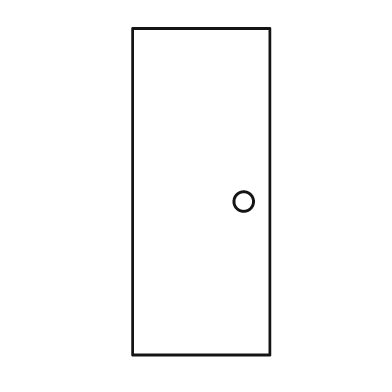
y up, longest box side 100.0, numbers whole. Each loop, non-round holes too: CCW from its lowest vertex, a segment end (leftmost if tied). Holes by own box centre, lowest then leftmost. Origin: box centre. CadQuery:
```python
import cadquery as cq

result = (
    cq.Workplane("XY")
    .moveTo(-21.0, -50.0)
    .lineTo(21.0, -50.0)
    .lineTo(21.0, 50.0)
    .lineTo(-21.0, 50.0)
    .close()
    .moveTo(13.0, -3.0)
    .circle(3.0)
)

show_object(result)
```